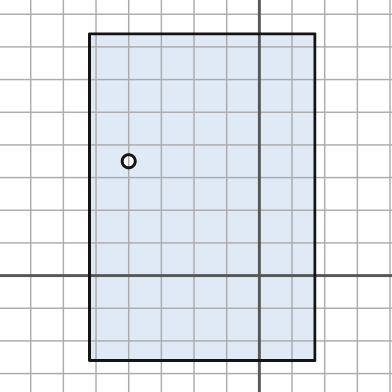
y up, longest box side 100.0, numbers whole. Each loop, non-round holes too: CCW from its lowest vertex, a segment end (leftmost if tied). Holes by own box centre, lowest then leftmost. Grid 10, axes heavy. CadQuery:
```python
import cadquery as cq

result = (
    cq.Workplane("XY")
    .moveTo(-52.0, -26.0)
    .lineTo(17.0, -26.0)
    .lineTo(17.0, 74.0)
    .lineTo(-52.0, 74.0)
    .close()
    .moveTo(-40.0, 35.0)
    .circle(2.0)
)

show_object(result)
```